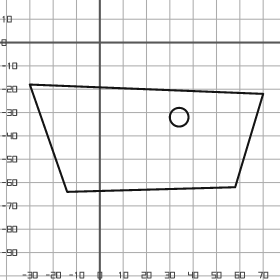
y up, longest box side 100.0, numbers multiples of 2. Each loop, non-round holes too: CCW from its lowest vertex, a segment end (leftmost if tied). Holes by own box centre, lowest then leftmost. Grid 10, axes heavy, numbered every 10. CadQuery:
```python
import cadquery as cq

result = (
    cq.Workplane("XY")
    .moveTo(-14.0, -64.0)
    .lineTo(58.0, -62.0)
    .lineTo(70.0, -22.0)
    .lineTo(-30.0, -18.0)
    .close()
    .moveTo(34.0, -32.0)
    .circle(4.0)
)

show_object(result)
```